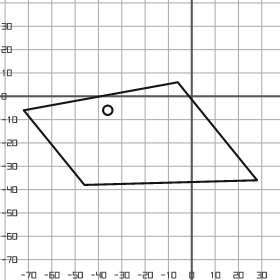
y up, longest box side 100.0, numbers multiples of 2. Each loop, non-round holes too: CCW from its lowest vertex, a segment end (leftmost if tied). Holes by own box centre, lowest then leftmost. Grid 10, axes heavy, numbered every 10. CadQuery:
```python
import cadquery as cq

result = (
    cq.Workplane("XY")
    .moveTo(-46.0, -38.0)
    .lineTo(28.0, -36.0)
    .lineTo(-6.0, 6.0)
    .lineTo(-72.0, -6.0)
    .close()
    .moveTo(-36.0, -6.0)
    .circle(2.0)
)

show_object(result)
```